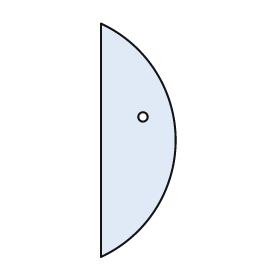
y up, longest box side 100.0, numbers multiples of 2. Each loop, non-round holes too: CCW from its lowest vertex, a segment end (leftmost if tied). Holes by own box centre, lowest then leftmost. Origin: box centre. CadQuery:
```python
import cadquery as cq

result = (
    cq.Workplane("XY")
    .moveTo(-16.0, -50.0)
    .threePointArc((16.0, 0.0), (-16.0, 50.0))
    .close()
    .moveTo(2.0, 10.0)
    .circle(2.0)
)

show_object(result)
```